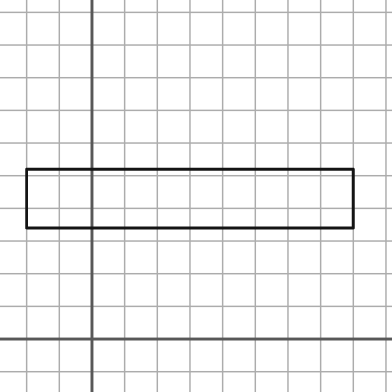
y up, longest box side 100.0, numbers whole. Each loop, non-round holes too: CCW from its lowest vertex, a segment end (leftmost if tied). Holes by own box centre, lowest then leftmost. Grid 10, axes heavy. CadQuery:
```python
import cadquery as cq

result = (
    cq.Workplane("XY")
    .moveTo(-20.0, 34.0)
    .lineTo(80.0, 34.0)
    .lineTo(80.0, 52.0)
    .lineTo(-20.0, 52.0)
    .close()
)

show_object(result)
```